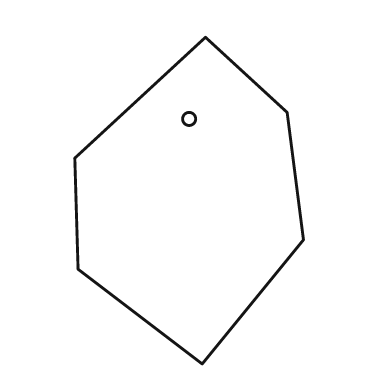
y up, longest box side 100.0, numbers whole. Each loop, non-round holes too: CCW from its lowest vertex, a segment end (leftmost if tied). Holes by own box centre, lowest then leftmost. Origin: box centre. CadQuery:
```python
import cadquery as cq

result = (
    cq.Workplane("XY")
    .moveTo(4.0, -50.0)
    .lineTo(35.0, -12.0)
    .lineTo(30.0, 27.0)
    .lineTo(5.0, 50.0)
    .lineTo(-35.0, 13.0)
    .lineTo(-34.0, -21.0)
    .close()
    .moveTo(0.0, 25.0)
    .circle(2.0)
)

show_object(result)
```